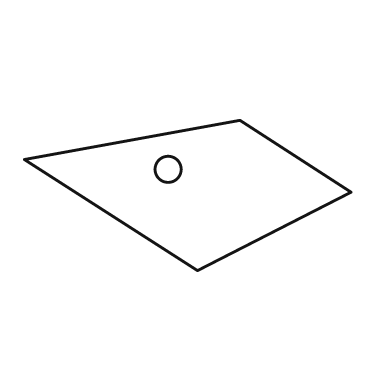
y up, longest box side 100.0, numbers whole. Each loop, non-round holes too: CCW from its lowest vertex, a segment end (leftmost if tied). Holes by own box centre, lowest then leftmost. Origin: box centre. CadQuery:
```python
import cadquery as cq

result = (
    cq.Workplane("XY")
    .moveTo(3.0, -23.0)
    .lineTo(50.0, 1.0)
    .lineTo(16.0, 23.0)
    .lineTo(-50.0, 11.0)
    .close()
    .moveTo(-6.0, 8.0)
    .circle(4.0)
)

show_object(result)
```